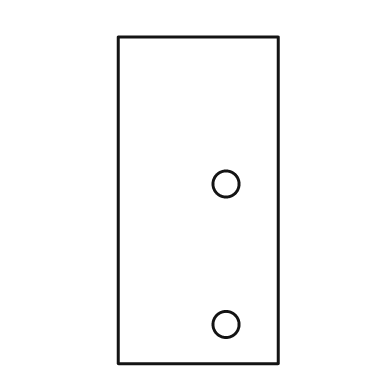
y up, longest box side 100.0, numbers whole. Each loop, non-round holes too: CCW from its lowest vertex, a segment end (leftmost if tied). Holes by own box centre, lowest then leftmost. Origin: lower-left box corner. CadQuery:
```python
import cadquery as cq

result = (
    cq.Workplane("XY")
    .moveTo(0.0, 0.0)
    .lineTo(49.0, 0.0)
    .lineTo(49.0, 100.0)
    .lineTo(0.0, 100.0)
    .close()
    .moveTo(33.0, 12.0)
    .circle(4.0)
    .moveTo(33.0, 55.0)
    .circle(4.0)
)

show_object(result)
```